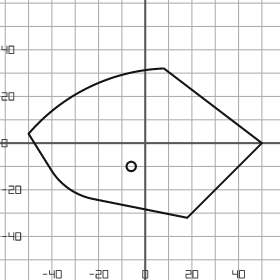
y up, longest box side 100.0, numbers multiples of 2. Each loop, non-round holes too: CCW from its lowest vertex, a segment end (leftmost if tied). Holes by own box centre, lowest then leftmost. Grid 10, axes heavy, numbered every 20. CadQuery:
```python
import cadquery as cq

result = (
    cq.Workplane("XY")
    .moveTo(18.0, -32.0)
    .lineTo(50.0, 0.0)
    .lineTo(8.0, 32.0)
    .threePointArc((-24.0, 24.0), (-50.0, 4.0))
    .lineTo(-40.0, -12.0)
    .threePointArc((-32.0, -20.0), (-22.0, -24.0))
    .close()
    .moveTo(-6.0, -10.0)
    .circle(2.0)
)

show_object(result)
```